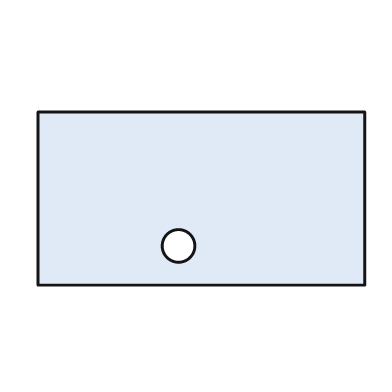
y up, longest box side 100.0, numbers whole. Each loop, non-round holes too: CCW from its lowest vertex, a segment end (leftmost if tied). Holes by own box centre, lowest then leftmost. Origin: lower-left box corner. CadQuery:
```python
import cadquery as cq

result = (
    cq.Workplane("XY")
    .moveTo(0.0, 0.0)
    .lineTo(100.0, 0.0)
    .lineTo(100.0, 53.0)
    .lineTo(0.0, 53.0)
    .close()
    .moveTo(43.0, 12.0)
    .circle(5.0)
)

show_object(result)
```